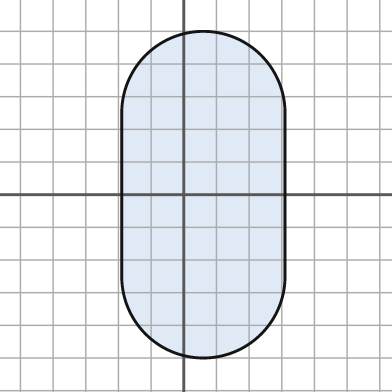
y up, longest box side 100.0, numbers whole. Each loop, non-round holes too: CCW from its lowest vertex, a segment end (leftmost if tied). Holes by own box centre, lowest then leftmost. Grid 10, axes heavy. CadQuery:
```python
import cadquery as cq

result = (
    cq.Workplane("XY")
    .moveTo(-19.0, -25.0)
    .threePointArc((6.0, -50.0), (31.0, -25.0))
    .lineTo(31.0, 25.0)
    .threePointArc((6.0, 50.0), (-19.0, 25.0))
    .close()
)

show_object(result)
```